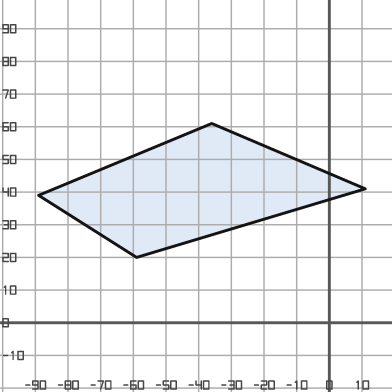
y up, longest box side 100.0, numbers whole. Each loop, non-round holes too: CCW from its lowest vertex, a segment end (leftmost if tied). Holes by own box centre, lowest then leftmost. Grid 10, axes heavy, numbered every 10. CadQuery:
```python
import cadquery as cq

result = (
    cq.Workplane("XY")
    .moveTo(-59.0, 20.0)
    .lineTo(11.0, 41.0)
    .lineTo(-36.0, 61.0)
    .lineTo(-89.0, 39.0)
    .close()
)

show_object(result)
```